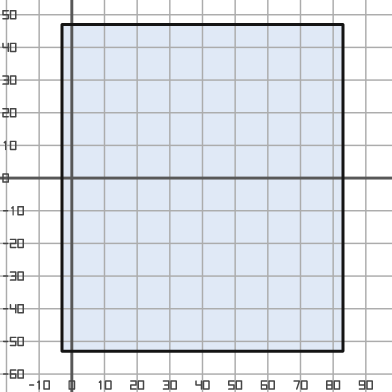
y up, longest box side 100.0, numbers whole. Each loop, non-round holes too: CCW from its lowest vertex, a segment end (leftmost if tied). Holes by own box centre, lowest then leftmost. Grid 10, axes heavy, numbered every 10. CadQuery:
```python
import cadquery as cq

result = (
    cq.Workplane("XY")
    .moveTo(-3.0, -53.0)
    .lineTo(83.0, -53.0)
    .lineTo(83.0, 47.0)
    .lineTo(-3.0, 47.0)
    .close()
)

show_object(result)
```